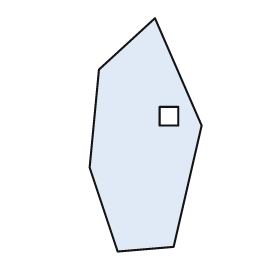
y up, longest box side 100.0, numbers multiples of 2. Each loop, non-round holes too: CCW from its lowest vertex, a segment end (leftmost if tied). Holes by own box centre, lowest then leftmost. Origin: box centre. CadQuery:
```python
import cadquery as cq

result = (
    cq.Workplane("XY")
    .moveTo(-12.0, -50.0)
    .lineTo(12.0, -48.0)
    .lineTo(24.0, 4.0)
    .lineTo(4.0, 50.0)
    .lineTo(-20.0, 28.0)
    .lineTo(-24.0, -14.0)
    .close()
    .moveTo(6.0, 4.0)
    .lineTo(14.0, 4.0)
    .lineTo(14.0, 12.0)
    .lineTo(6.0, 12.0)
    .close()
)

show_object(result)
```